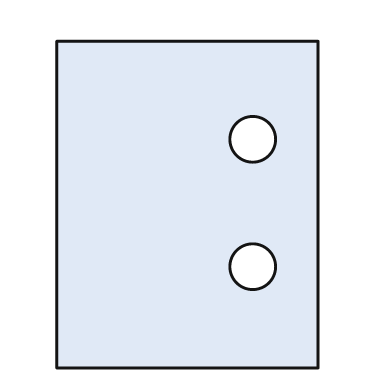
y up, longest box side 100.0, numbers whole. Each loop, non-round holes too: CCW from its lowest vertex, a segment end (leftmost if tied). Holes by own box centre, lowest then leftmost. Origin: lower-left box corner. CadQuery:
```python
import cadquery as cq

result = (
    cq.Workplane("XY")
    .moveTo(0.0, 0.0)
    .lineTo(80.0, 0.0)
    .lineTo(80.0, 100.0)
    .lineTo(0.0, 100.0)
    .close()
    .moveTo(60.0, 31.0)
    .circle(7.0)
    .moveTo(60.0, 70.0)
    .circle(7.0)
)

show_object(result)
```